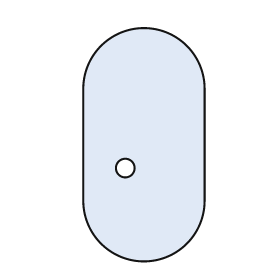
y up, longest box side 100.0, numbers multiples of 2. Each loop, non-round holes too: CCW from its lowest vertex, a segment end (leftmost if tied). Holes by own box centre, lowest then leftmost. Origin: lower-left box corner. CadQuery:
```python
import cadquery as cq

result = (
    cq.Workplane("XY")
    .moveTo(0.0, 26.0)
    .threePointArc((26.0, 0.0), (52.0, 26.0))
    .lineTo(52.0, 74.0)
    .threePointArc((26.0, 100.0), (0.0, 74.0))
    .close()
    .moveTo(18.0, 40.0)
    .circle(4.0)
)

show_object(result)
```